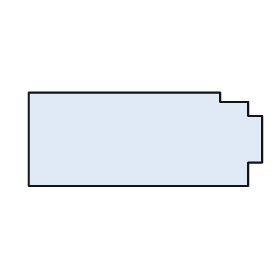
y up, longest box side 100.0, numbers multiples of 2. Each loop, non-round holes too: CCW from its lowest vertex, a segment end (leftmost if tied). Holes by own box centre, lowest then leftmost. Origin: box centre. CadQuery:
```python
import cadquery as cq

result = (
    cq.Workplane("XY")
    .moveTo(-50.0, -20.0)
    .lineTo(44.0, -20.0)
    .lineTo(44.0, -10.0)
    .lineTo(50.0, -10.0)
    .lineTo(50.0, 10.0)
    .lineTo(44.0, 10.0)
    .lineTo(44.0, 16.0)
    .lineTo(32.0, 16.0)
    .lineTo(32.0, 20.0)
    .lineTo(-50.0, 20.0)
    .close()
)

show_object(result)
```